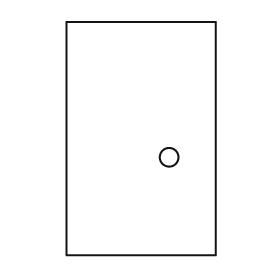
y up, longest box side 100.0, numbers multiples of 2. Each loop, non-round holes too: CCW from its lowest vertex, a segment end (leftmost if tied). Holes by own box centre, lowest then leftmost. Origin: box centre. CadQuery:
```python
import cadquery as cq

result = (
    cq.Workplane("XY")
    .moveTo(-32.0, -50.0)
    .lineTo(32.0, -50.0)
    .lineTo(32.0, 50.0)
    .lineTo(-32.0, 50.0)
    .close()
    .moveTo(12.0, -8.0)
    .circle(4.0)
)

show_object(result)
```